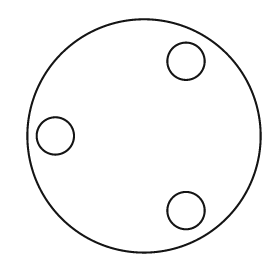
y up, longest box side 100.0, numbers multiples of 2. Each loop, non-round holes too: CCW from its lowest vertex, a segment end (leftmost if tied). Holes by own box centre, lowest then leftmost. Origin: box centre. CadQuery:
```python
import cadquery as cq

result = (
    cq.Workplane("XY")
    .moveTo(0.0, 0.0)
    .circle(50.0)
    .moveTo(18.0, -32.0)
    .circle(8.0)
    .moveTo(-38.0, 0.0)
    .circle(8.0)
    .moveTo(18.0, 32.0)
    .circle(8.0)
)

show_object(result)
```